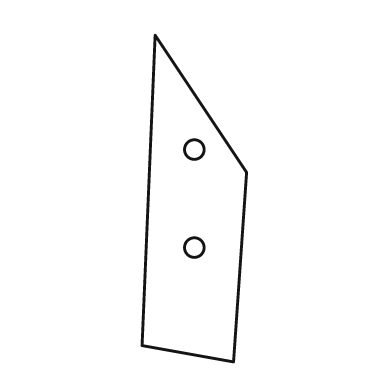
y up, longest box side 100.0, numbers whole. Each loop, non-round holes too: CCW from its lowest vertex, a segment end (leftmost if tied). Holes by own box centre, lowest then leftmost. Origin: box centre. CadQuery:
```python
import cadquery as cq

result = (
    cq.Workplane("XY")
    .moveTo(12.0, -50.0)
    .lineTo(16.0, 8.0)
    .lineTo(-12.0, 50.0)
    .lineTo(-16.0, -45.0)
    .close()
    .moveTo(0.0, -15.0)
    .circle(3.0)
    .moveTo(0.0, 15.0)
    .circle(3.0)
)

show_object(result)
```